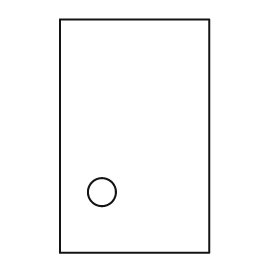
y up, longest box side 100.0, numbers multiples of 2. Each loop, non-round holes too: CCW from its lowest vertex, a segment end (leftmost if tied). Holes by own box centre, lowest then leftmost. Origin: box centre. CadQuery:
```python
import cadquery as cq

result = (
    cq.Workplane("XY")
    .moveTo(-32.0, -50.0)
    .lineTo(32.0, -50.0)
    .lineTo(32.0, 50.0)
    .lineTo(-32.0, 50.0)
    .close()
    .moveTo(-14.0, -24.0)
    .circle(6.0)
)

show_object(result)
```